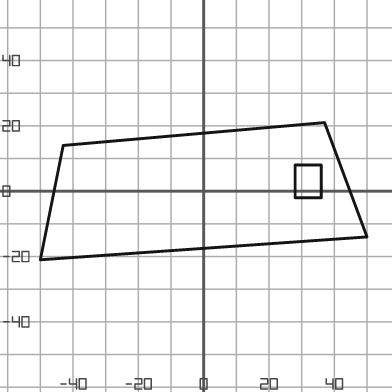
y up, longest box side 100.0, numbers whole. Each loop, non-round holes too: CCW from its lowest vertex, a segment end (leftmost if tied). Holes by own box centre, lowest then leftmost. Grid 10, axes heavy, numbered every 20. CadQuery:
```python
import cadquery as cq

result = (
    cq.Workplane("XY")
    .moveTo(-50.0, -21.0)
    .lineTo(50.0, -14.0)
    .lineTo(37.0, 21.0)
    .lineTo(-43.0, 14.0)
    .close()
    .moveTo(28.0, -2.0)
    .lineTo(36.0, -2.0)
    .lineTo(36.0, 8.0)
    .lineTo(28.0, 8.0)
    .close()
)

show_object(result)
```